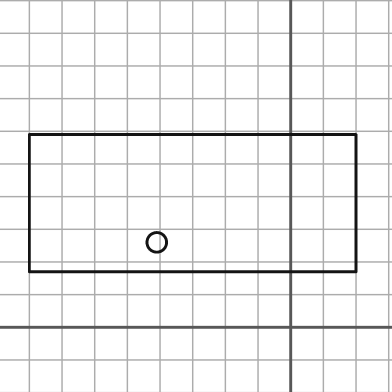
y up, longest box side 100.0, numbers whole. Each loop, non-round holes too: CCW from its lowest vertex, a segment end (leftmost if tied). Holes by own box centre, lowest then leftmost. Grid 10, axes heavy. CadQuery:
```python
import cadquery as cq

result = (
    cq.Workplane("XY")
    .moveTo(-80.0, 17.0)
    .lineTo(20.0, 17.0)
    .lineTo(20.0, 59.0)
    .lineTo(-80.0, 59.0)
    .close()
    .moveTo(-41.0, 26.0)
    .circle(3.0)
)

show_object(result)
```